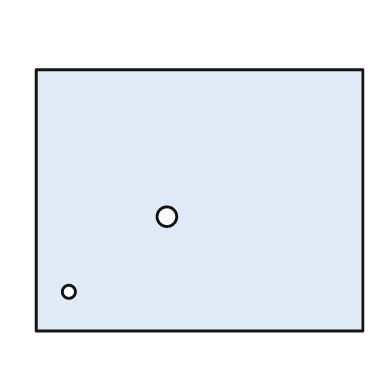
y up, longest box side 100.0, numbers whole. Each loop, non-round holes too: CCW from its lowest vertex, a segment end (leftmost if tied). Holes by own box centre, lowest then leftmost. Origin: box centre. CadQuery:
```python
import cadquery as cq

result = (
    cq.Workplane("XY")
    .moveTo(-50.0, -40.0)
    .lineTo(50.0, -40.0)
    .lineTo(50.0, 40.0)
    .lineTo(-50.0, 40.0)
    .close()
    .moveTo(-40.0, -28.0)
    .circle(2.0)
    .moveTo(-10.0, -5.0)
    .circle(3.0)
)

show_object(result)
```